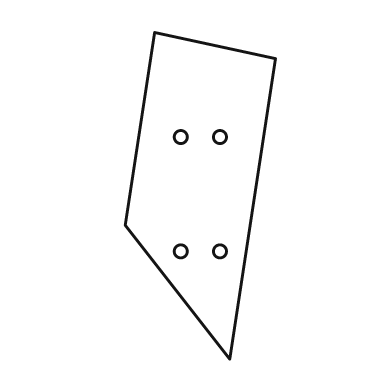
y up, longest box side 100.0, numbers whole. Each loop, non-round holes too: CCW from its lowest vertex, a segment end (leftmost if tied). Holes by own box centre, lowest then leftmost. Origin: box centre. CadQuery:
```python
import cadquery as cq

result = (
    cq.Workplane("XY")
    .moveTo(9.0, -50.0)
    .lineTo(23.0, 42.0)
    .lineTo(-14.0, 50.0)
    .lineTo(-23.0, -9.0)
    .close()
    .moveTo(-6.0, -17.0)
    .circle(2.0)
    .moveTo(6.0, -17.0)
    .circle(2.0)
    .moveTo(-6.0, 18.0)
    .circle(2.0)
    .moveTo(6.0, 18.0)
    .circle(2.0)
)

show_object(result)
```